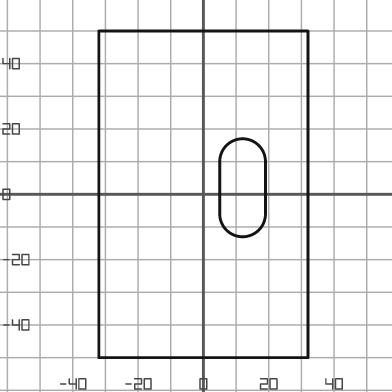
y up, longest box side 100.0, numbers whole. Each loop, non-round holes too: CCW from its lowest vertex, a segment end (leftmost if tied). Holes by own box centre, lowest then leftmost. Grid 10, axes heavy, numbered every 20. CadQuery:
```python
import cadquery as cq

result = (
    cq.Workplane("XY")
    .moveTo(-32.0, -50.0)
    .lineTo(32.0, -50.0)
    .lineTo(32.0, 50.0)
    .lineTo(-32.0, 50.0)
    .close()
    .moveTo(5.0, -6.0)
    .threePointArc((12.0, -13.0), (19.0, -6.0))
    .lineTo(19.0, 10.0)
    .threePointArc((12.0, 17.0), (5.0, 10.0))
    .close()
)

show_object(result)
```